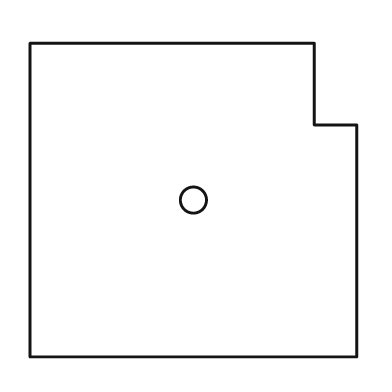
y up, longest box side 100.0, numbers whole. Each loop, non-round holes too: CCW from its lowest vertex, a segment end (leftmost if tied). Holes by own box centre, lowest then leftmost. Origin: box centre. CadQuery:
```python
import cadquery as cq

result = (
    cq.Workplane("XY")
    .moveTo(-50.0, -48.0)
    .lineTo(50.0, -48.0)
    .lineTo(50.0, 23.0)
    .lineTo(37.0, 23.0)
    .lineTo(37.0, 48.0)
    .lineTo(-50.0, 48.0)
    .close()
    .moveTo(0.0, 0.0)
    .circle(4.0)
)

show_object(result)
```